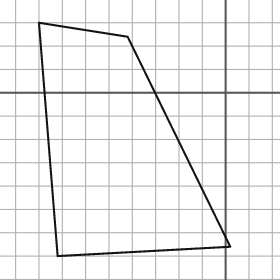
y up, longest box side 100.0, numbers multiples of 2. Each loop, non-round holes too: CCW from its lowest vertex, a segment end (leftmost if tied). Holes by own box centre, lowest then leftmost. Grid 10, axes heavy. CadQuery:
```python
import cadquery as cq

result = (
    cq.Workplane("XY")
    .moveTo(-72.0, -70.0)
    .lineTo(2.0, -66.0)
    .lineTo(-42.0, 24.0)
    .lineTo(-80.0, 30.0)
    .close()
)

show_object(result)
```